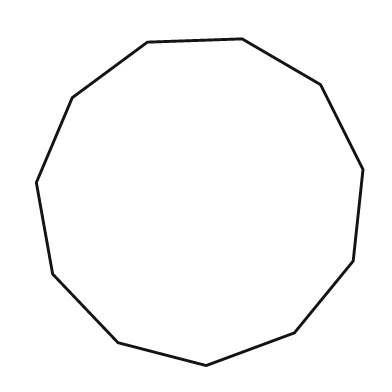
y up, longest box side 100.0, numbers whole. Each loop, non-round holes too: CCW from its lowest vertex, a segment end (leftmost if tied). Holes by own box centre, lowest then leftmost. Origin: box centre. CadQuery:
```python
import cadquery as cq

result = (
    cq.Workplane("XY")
    .moveTo(2.0, -50.0)
    .lineTo(29.0, -40.0)
    .lineTo(47.0, -18.0)
    .lineTo(50.0, 10.0)
    .lineTo(37.0, 36.0)
    .lineTo(13.0, 50.0)
    .lineTo(-16.0, 49.0)
    .lineTo(-39.0, 32.0)
    .lineTo(-50.0, 6.0)
    .lineTo(-45.0, -22.0)
    .lineTo(-25.0, -43.0)
    .close()
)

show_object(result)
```